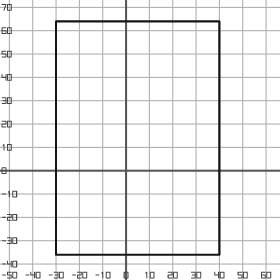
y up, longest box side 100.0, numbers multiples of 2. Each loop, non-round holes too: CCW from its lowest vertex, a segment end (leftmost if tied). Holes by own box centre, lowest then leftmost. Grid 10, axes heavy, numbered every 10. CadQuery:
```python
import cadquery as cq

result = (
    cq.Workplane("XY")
    .moveTo(-30.0, -36.0)
    .lineTo(40.0, -36.0)
    .lineTo(40.0, 64.0)
    .lineTo(-30.0, 64.0)
    .close()
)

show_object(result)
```